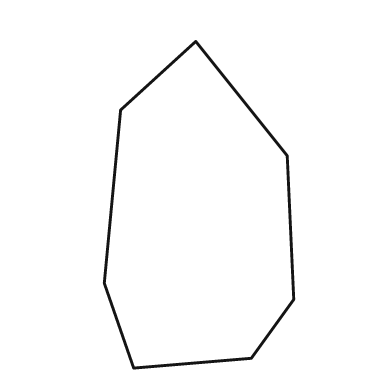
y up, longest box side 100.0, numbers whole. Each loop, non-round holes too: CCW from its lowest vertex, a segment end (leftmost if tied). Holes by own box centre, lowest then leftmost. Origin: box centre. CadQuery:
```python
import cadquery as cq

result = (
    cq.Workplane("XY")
    .moveTo(-20.0, -50.0)
    .lineTo(16.0, -47.0)
    .lineTo(29.0, -29.0)
    .lineTo(27.0, 15.0)
    .lineTo(-1.0, 50.0)
    .lineTo(-24.0, 29.0)
    .lineTo(-29.0, -24.0)
    .close()
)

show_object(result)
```